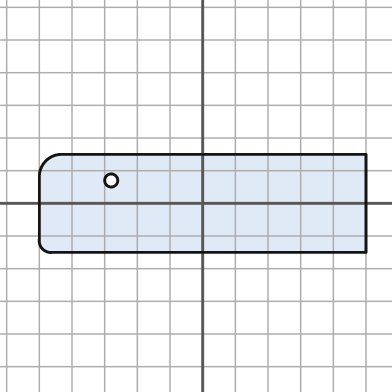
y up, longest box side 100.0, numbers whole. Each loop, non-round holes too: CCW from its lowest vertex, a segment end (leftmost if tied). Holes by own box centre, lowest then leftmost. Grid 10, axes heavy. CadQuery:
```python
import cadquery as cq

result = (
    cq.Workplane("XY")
    .moveTo(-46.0, -15.0)
    .lineTo(50.0, -15.0)
    .lineTo(50.0, 15.0)
    .lineTo(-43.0, 15.0)
    .threePointArc((-48.0, 13.0), (-50.0, 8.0))
    .lineTo(-50.0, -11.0)
    .threePointArc((-49.0, -14.0), (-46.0, -15.0))
    .close()
    .moveTo(-28.0, 7.0)
    .circle(2.0)
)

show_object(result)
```